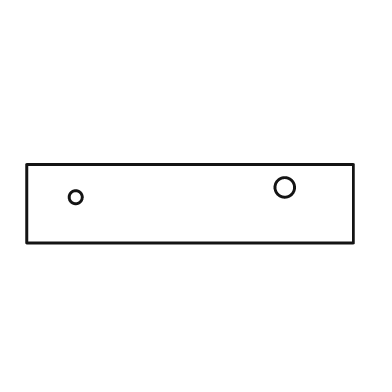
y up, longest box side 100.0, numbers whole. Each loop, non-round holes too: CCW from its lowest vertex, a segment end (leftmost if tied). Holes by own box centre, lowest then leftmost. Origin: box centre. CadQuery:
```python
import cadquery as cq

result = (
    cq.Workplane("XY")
    .moveTo(-50.0, -12.0)
    .lineTo(50.0, -12.0)
    .lineTo(50.0, 12.0)
    .lineTo(-50.0, 12.0)
    .close()
    .moveTo(-35.0, 2.0)
    .circle(2.0)
    .moveTo(29.0, 5.0)
    .circle(3.0)
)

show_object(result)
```